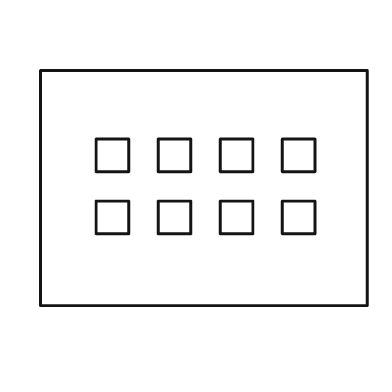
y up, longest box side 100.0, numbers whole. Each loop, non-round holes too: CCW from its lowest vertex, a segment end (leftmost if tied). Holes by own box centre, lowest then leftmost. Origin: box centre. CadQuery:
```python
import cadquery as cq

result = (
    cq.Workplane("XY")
    .moveTo(-50.0, -36.0)
    .lineTo(50.0, -36.0)
    .lineTo(50.0, 36.0)
    .lineTo(-50.0, 36.0)
    .close()
    .moveTo(-33.0, -14.0)
    .lineTo(-23.0, -14.0)
    .lineTo(-23.0, -4.0)
    .lineTo(-33.0, -4.0)
    .close()
    .moveTo(-14.0, -14.0)
    .lineTo(-4.0, -14.0)
    .lineTo(-4.0, -4.0)
    .lineTo(-14.0, -4.0)
    .close()
    .moveTo(5.0, -14.0)
    .lineTo(15.0, -14.0)
    .lineTo(15.0, -4.0)
    .lineTo(5.0, -4.0)
    .close()
    .moveTo(24.0, -14.0)
    .lineTo(34.0, -14.0)
    .lineTo(34.0, -4.0)
    .lineTo(24.0, -4.0)
    .close()
    .moveTo(-33.0, 5.0)
    .lineTo(-23.0, 5.0)
    .lineTo(-23.0, 15.0)
    .lineTo(-33.0, 15.0)
    .close()
    .moveTo(-14.0, 5.0)
    .lineTo(-4.0, 5.0)
    .lineTo(-4.0, 15.0)
    .lineTo(-14.0, 15.0)
    .close()
    .moveTo(5.0, 5.0)
    .lineTo(15.0, 5.0)
    .lineTo(15.0, 15.0)
    .lineTo(5.0, 15.0)
    .close()
    .moveTo(24.0, 5.0)
    .lineTo(34.0, 5.0)
    .lineTo(34.0, 15.0)
    .lineTo(24.0, 15.0)
    .close()
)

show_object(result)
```